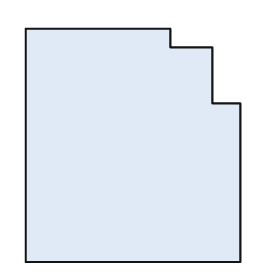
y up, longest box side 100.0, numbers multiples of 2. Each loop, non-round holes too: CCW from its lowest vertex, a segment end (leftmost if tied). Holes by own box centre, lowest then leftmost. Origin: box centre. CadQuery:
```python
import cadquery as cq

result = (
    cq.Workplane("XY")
    .moveTo(-46.0, -50.0)
    .lineTo(46.0, -50.0)
    .lineTo(46.0, 18.0)
    .lineTo(34.0, 18.0)
    .lineTo(34.0, 42.0)
    .lineTo(16.0, 42.0)
    .lineTo(16.0, 50.0)
    .lineTo(-46.0, 50.0)
    .close()
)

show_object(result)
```